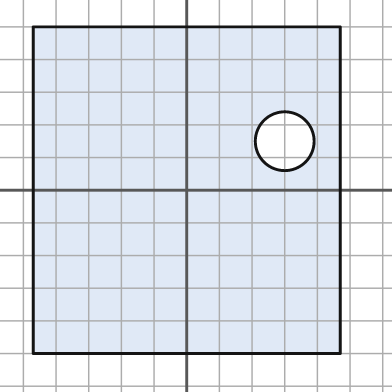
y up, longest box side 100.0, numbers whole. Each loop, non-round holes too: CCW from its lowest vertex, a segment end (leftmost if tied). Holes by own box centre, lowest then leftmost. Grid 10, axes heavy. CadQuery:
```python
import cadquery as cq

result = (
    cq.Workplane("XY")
    .moveTo(-47.0, -50.0)
    .lineTo(47.0, -50.0)
    .lineTo(47.0, 50.0)
    .lineTo(-47.0, 50.0)
    .close()
    .moveTo(30.0, 15.0)
    .circle(9.0)
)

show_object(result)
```